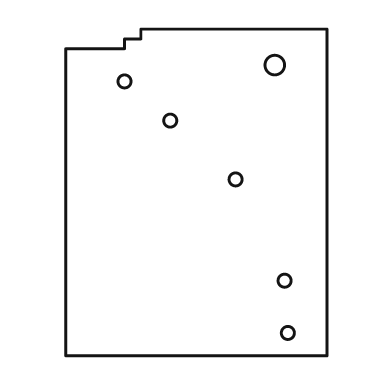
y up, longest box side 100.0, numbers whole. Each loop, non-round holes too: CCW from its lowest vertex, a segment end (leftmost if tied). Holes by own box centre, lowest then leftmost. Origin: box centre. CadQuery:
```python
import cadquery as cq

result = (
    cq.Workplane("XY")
    .moveTo(-40.0, -50.0)
    .lineTo(40.0, -50.0)
    .lineTo(40.0, 50.0)
    .lineTo(-17.0, 50.0)
    .lineTo(-17.0, 47.0)
    .lineTo(-22.0, 47.0)
    .lineTo(-22.0, 44.0)
    .lineTo(-40.0, 44.0)
    .close()
    .moveTo(28.0, -43.0)
    .circle(2.0)
    .moveTo(27.0, -27.0)
    .circle(2.0)
    .moveTo(12.0, 4.0)
    .circle(2.0)
    .moveTo(-8.0, 22.0)
    .circle(2.0)
    .moveTo(-22.0, 34.0)
    .circle(2.0)
    .moveTo(24.0, 39.0)
    .circle(3.0)
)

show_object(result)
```